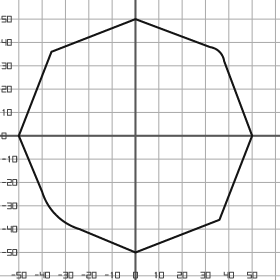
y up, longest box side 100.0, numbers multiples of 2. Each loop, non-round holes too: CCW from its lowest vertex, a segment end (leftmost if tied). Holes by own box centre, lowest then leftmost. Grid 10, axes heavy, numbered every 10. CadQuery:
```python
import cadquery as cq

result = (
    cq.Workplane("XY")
    .moveTo(0.0, -50.0)
    .lineTo(36.0, -36.0)
    .lineTo(50.0, 0.0)
    .lineTo(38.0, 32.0)
    .threePointArc((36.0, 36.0), (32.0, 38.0))
    .lineTo(0.0, 50.0)
    .lineTo(-36.0, 36.0)
    .lineTo(-50.0, 0.0)
    .lineTo(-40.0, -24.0)
    .threePointArc((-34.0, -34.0), (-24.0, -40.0))
    .close()
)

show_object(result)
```